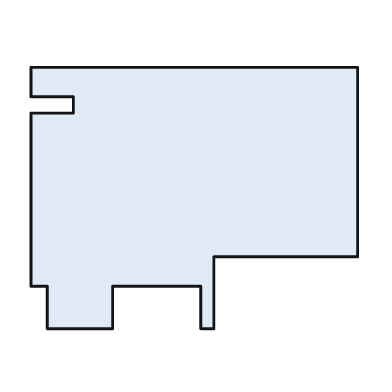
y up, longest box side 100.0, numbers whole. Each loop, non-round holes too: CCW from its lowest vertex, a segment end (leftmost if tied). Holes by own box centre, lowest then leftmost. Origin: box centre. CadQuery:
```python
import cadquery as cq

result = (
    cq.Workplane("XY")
    .moveTo(-45.0, -40.0)
    .lineTo(-25.0, -40.0)
    .lineTo(-25.0, -27.0)
    .lineTo(2.0, -27.0)
    .lineTo(2.0, -40.0)
    .lineTo(6.0, -40.0)
    .lineTo(6.0, -18.0)
    .lineTo(50.0, -18.0)
    .lineTo(50.0, 40.0)
    .lineTo(-50.0, 40.0)
    .lineTo(-50.0, 31.0)
    .lineTo(-37.0, 31.0)
    .lineTo(-37.0, 26.0)
    .lineTo(-50.0, 26.0)
    .lineTo(-50.0, -27.0)
    .lineTo(-45.0, -27.0)
    .close()
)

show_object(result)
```